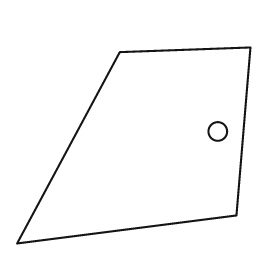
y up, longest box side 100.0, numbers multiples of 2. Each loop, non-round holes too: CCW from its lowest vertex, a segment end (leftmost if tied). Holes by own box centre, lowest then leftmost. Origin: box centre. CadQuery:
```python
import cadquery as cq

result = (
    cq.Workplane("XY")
    .moveTo(-50.0, -42.0)
    .lineTo(44.0, -30.0)
    .lineTo(50.0, 42.0)
    .lineTo(-6.0, 40.0)
    .close()
    .moveTo(36.0, 6.0)
    .circle(4.0)
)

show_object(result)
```